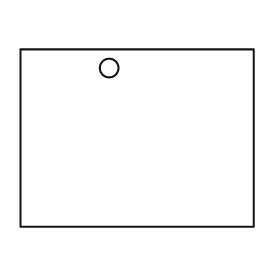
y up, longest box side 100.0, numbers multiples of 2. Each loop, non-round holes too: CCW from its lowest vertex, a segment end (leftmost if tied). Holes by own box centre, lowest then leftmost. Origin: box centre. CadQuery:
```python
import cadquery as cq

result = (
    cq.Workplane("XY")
    .moveTo(-50.0, -38.0)
    .lineTo(50.0, -38.0)
    .lineTo(50.0, 38.0)
    .lineTo(-50.0, 38.0)
    .close()
    .moveTo(-12.0, 30.0)
    .circle(4.0)
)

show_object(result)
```